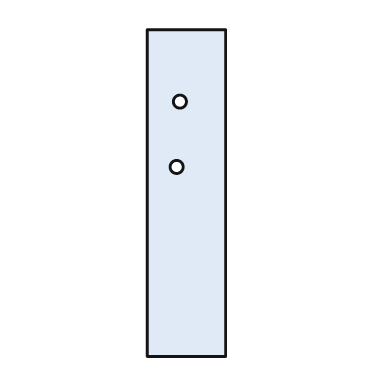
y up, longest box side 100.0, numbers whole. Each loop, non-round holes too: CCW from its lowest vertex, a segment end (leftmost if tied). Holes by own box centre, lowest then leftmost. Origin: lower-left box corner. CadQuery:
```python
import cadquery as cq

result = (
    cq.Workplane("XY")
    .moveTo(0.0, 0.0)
    .lineTo(24.0, 0.0)
    .lineTo(24.0, 100.0)
    .lineTo(0.0, 100.0)
    .close()
    .moveTo(9.0, 58.0)
    .circle(2.0)
    .moveTo(10.0, 78.0)
    .circle(2.0)
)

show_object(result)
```